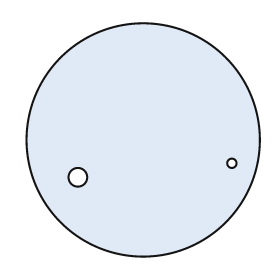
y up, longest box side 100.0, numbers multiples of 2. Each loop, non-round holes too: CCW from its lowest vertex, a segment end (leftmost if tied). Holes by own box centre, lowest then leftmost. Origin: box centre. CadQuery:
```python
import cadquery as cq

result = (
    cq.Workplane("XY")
    .moveTo(0.0, 0.0)
    .circle(50.0)
    .moveTo(-28.0, -16.0)
    .circle(4.0)
    .moveTo(38.0, -10.0)
    .circle(2.0)
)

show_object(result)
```